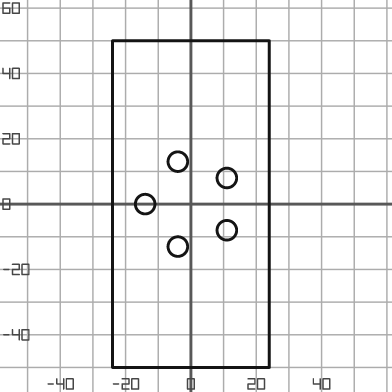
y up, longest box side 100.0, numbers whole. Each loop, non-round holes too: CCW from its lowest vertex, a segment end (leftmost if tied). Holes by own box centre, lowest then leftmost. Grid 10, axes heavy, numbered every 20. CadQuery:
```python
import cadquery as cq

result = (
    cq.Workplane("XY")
    .moveTo(-24.0, -50.0)
    .lineTo(24.0, -50.0)
    .lineTo(24.0, 50.0)
    .lineTo(-24.0, 50.0)
    .close()
    .moveTo(-4.0, -13.0)
    .circle(3.0)
    .moveTo(11.0, -8.0)
    .circle(3.0)
    .moveTo(-14.0, 0.0)
    .circle(3.0)
    .moveTo(11.0, 8.0)
    .circle(3.0)
    .moveTo(-4.0, 13.0)
    .circle(3.0)
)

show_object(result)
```